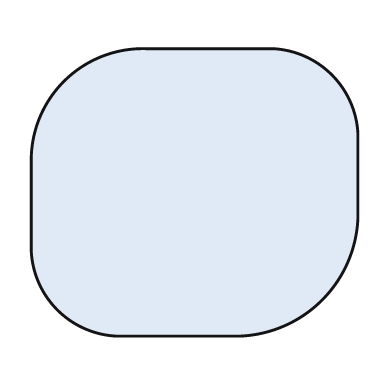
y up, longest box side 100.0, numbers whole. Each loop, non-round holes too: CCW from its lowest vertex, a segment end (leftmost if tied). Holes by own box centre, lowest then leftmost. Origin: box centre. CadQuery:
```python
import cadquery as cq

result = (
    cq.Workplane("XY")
    .moveTo(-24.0, -44.0)
    .lineTo(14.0, -44.0)
    .threePointArc((39.0, -33.0), (50.0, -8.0))
    .lineTo(50.0, 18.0)
    .threePointArc((42.0, 36.0), (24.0, 44.0))
    .lineTo(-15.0, 44.0)
    .threePointArc((-40.0, 34.0), (-50.0, 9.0))
    .lineTo(-50.0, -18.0)
    .threePointArc((-42.0, -36.0), (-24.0, -44.0))
    .close()
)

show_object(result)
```